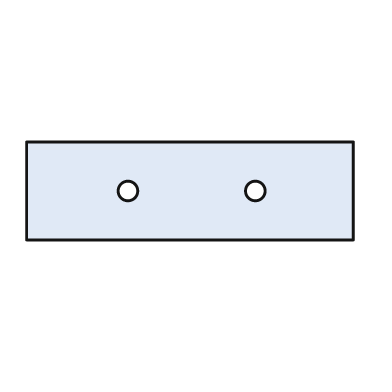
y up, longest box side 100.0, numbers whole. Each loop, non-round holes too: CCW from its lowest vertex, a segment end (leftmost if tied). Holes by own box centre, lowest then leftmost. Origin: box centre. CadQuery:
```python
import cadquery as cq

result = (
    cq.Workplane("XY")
    .moveTo(-50.0, -15.0)
    .lineTo(50.0, -15.0)
    .lineTo(50.0, 15.0)
    .lineTo(-50.0, 15.0)
    .close()
    .moveTo(-19.0, 0.0)
    .circle(3.0)
    .moveTo(20.0, 0.0)
    .circle(3.0)
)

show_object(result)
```